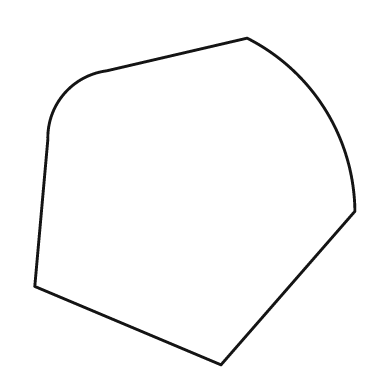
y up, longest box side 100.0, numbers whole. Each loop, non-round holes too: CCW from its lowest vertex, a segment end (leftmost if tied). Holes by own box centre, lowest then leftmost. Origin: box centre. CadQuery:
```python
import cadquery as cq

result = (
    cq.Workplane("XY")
    .moveTo(8.0, -50.0)
    .lineTo(49.0, -3.0)
    .threePointArc((40.0, 28.0), (16.0, 50.0))
    .lineTo(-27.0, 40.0)
    .threePointArc((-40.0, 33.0), (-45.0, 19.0))
    .lineTo(-49.0, -26.0)
    .close()
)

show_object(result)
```